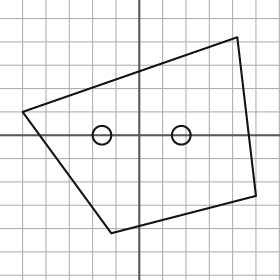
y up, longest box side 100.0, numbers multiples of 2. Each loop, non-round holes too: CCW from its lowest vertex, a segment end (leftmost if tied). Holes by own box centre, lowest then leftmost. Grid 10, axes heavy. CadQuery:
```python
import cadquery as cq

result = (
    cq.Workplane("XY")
    .moveTo(-12.0, -42.0)
    .lineTo(50.0, -26.0)
    .lineTo(42.0, 42.0)
    .lineTo(-50.0, 10.0)
    .close()
    .moveTo(-16.0, 0.0)
    .circle(4.0)
    .moveTo(18.0, 0.0)
    .circle(4.0)
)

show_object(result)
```